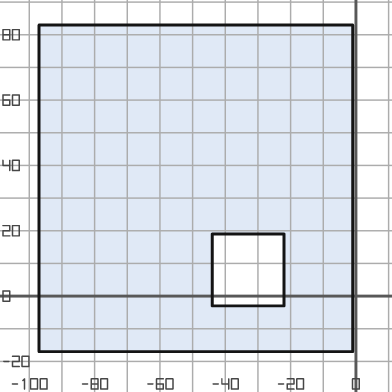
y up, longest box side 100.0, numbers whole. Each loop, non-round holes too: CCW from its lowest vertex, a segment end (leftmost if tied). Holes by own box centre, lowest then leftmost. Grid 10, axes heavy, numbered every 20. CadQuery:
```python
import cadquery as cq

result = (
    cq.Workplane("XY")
    .moveTo(-97.0, -17.0)
    .lineTo(-1.0, -17.0)
    .lineTo(-1.0, 83.0)
    .lineTo(-97.0, 83.0)
    .close()
    .moveTo(-44.0, -3.0)
    .lineTo(-22.0, -3.0)
    .lineTo(-22.0, 19.0)
    .lineTo(-44.0, 19.0)
    .close()
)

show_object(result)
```